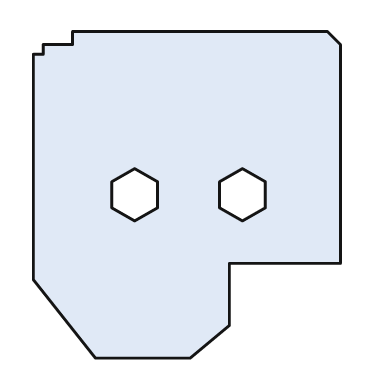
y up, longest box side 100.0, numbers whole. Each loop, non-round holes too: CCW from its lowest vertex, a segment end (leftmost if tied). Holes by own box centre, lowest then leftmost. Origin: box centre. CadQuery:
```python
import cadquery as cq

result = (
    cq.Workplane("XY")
    .moveTo(-28.0, -50.0)
    .lineTo(1.0, -50.0)
    .lineTo(13.0, -40.0)
    .lineTo(13.0, -21.0)
    .lineTo(47.0, -21.0)
    .lineTo(47.0, 46.0)
    .lineTo(43.0, 50.0)
    .lineTo(-35.0, 50.0)
    .lineTo(-35.0, 46.0)
    .lineTo(-44.0, 46.0)
    .lineTo(-44.0, 43.0)
    .lineTo(-47.0, 43.0)
    .lineTo(-47.0, -26.0)
    .close()
    .moveTo(-16.0, -8.0)
    .lineTo(-9.0, -4.0)
    .lineTo(-9.0, 4.0)
    .lineTo(-16.0, 8.0)
    .lineTo(-23.0, 4.0)
    .lineTo(-23.0, -4.0)
    .close()
    .moveTo(17.0, -8.0)
    .lineTo(24.0, -4.0)
    .lineTo(24.0, 4.0)
    .lineTo(17.0, 8.0)
    .lineTo(10.0, 4.0)
    .lineTo(10.0, -4.0)
    .close()
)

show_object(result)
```